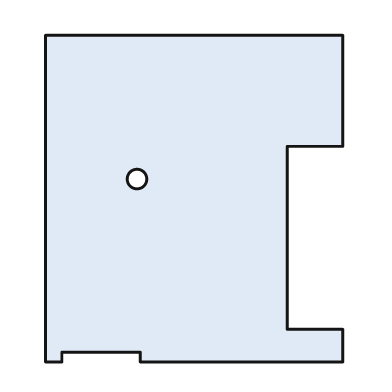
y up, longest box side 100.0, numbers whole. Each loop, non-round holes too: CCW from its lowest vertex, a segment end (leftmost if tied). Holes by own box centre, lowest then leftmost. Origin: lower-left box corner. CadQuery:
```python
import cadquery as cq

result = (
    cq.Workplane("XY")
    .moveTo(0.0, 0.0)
    .lineTo(5.0, 0.0)
    .lineTo(5.0, 3.0)
    .lineTo(29.0, 3.0)
    .lineTo(29.0, 0.0)
    .lineTo(91.0, 0.0)
    .lineTo(91.0, 10.0)
    .lineTo(74.0, 10.0)
    .lineTo(74.0, 66.0)
    .lineTo(91.0, 66.0)
    .lineTo(91.0, 100.0)
    .lineTo(0.0, 100.0)
    .close()
    .moveTo(28.0, 56.0)
    .circle(3.0)
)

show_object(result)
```